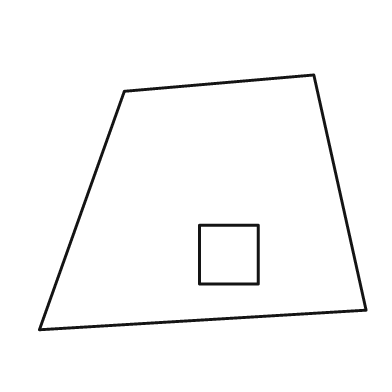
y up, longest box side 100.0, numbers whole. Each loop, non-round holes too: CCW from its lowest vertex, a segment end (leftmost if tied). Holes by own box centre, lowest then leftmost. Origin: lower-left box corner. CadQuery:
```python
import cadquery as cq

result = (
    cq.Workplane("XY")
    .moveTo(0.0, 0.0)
    .lineTo(100.0, 6.0)
    .lineTo(84.0, 78.0)
    .lineTo(26.0, 73.0)
    .close()
    .moveTo(49.0, 14.0)
    .lineTo(67.0, 14.0)
    .lineTo(67.0, 32.0)
    .lineTo(49.0, 32.0)
    .close()
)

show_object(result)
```